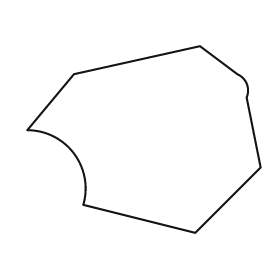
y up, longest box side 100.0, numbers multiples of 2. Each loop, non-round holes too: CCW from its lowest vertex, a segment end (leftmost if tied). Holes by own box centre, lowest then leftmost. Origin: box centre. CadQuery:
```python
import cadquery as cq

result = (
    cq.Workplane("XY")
    .moveTo(22.0, -40.0)
    .lineTo(50.0, -12.0)
    .lineTo(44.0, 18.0)
    .threePointArc((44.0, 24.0), (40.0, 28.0))
    .lineTo(24.0, 40.0)
    .lineTo(-30.0, 28.0)
    .lineTo(-50.0, 4.0)
    .threePointArc((-30.0, -6.0), (-26.0, -28.0))
    .close()
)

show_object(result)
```